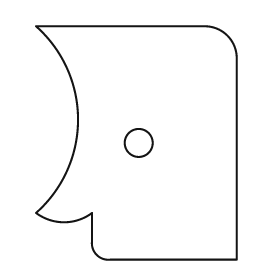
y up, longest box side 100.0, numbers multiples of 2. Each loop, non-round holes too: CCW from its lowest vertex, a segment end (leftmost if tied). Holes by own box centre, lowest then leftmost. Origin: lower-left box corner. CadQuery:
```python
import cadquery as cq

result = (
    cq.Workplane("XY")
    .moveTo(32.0, 0.0)
    .lineTo(86.0, 0.0)
    .lineTo(86.0, 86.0)
    .threePointArc((82.0, 96.0), (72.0, 100.0))
    .lineTo(0.0, 100.0)
    .threePointArc((18.0, 60.0), (0.0, 20.0))
    .threePointArc((12.0, 16.0), (24.0, 20.0))
    .lineTo(24.0, 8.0)
    .threePointArc((26.0, 2.0), (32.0, 0.0))
    .close()
    .moveTo(44.0, 50.0)
    .circle(6.0)
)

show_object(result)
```